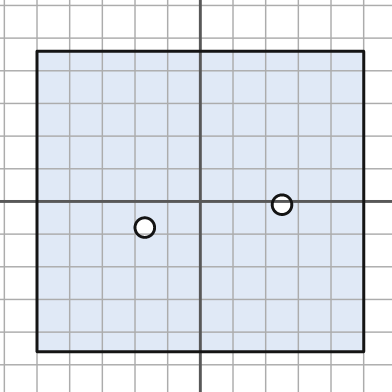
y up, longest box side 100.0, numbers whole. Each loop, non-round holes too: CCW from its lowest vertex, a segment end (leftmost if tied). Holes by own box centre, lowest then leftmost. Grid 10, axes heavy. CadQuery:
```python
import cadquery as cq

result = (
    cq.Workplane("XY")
    .moveTo(-50.0, -46.0)
    .lineTo(50.0, -46.0)
    .lineTo(50.0, 46.0)
    .lineTo(-50.0, 46.0)
    .close()
    .moveTo(-17.0, -8.0)
    .circle(3.0)
    .moveTo(25.0, -1.0)
    .circle(3.0)
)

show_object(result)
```